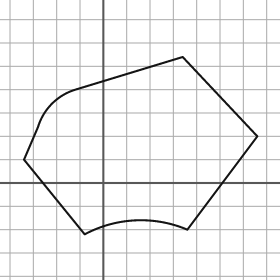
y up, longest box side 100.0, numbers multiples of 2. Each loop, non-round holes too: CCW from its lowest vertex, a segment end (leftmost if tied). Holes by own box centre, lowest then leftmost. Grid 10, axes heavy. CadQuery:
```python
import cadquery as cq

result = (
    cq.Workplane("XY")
    .moveTo(-8.0, -22.0)
    .threePointArc((14.0, -16.0), (36.0, -20.0))
    .lineTo(66.0, 20.0)
    .lineTo(34.0, 54.0)
    .lineTo(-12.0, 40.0)
    .threePointArc((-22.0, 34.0), (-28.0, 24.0))
    .lineTo(-34.0, 10.0)
    .close()
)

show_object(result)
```